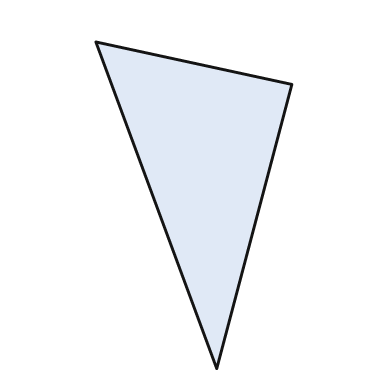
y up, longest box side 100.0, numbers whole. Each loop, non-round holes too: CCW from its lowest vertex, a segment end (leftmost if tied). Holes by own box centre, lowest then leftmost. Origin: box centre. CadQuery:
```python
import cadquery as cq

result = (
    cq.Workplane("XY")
    .moveTo(7.0, -50.0)
    .lineTo(30.0, 37.0)
    .lineTo(-30.0, 50.0)
    .close()
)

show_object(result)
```